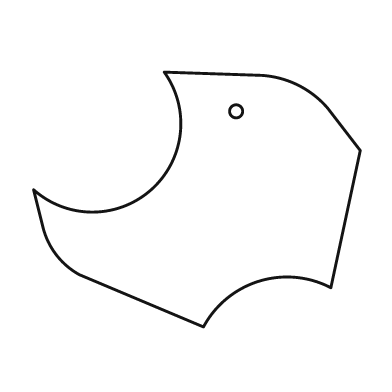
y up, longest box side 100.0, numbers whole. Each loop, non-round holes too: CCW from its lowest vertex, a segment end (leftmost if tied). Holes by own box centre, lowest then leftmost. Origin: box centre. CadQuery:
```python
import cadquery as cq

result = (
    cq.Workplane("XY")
    .moveTo(2.0, -39.0)
    .threePointArc((19.0, -25.0), (41.0, -27.0))
    .lineTo(50.0, 15.0)
    .lineTo(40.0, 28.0)
    .threePointArc((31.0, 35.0), (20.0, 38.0))
    .lineTo(-10.0, 39.0)
    .threePointArc((-14.0, 3.0), (-50.0, 3.0))
    .lineTo(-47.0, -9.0)
    .threePointArc((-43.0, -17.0), (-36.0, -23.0))
    .close()
    .moveTo(12.0, 27.0)
    .circle(2.0)
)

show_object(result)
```